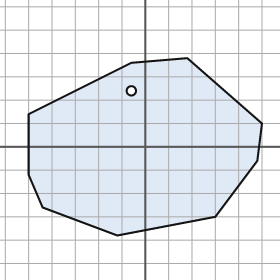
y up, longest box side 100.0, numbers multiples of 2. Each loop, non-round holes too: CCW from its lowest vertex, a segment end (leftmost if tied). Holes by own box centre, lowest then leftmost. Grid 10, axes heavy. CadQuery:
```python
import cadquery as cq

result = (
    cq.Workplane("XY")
    .moveTo(-12.0, -38.0)
    .lineTo(30.0, -30.0)
    .lineTo(48.0, -6.0)
    .lineTo(50.0, 10.0)
    .lineTo(18.0, 38.0)
    .lineTo(-6.0, 36.0)
    .lineTo(-50.0, 14.0)
    .lineTo(-50.0, -12.0)
    .lineTo(-44.0, -26.0)
    .close()
    .moveTo(-6.0, 24.0)
    .circle(2.0)
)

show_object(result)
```